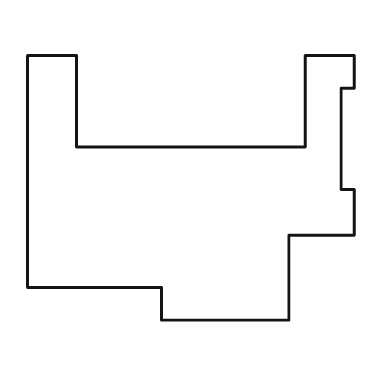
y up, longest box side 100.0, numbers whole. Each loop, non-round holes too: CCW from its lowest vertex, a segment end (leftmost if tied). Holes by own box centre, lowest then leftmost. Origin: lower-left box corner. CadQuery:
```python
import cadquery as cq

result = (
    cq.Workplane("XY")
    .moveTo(41.0, 0.0)
    .lineTo(80.0, 0.0)
    .lineTo(80.0, 26.0)
    .lineTo(100.0, 26.0)
    .lineTo(100.0, 40.0)
    .lineTo(96.0, 40.0)
    .lineTo(96.0, 71.0)
    .lineTo(100.0, 71.0)
    .lineTo(100.0, 81.0)
    .lineTo(85.0, 81.0)
    .lineTo(85.0, 53.0)
    .lineTo(15.0, 53.0)
    .lineTo(15.0, 81.0)
    .lineTo(0.0, 81.0)
    .lineTo(0.0, 10.0)
    .lineTo(41.0, 10.0)
    .close()
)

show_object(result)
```